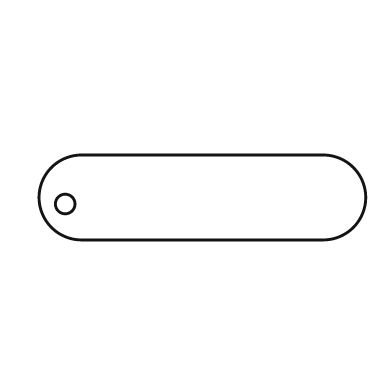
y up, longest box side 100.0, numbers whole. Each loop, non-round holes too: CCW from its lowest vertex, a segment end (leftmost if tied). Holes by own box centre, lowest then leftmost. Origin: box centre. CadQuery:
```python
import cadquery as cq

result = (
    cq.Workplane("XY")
    .moveTo(-37.0, -13.0)
    .lineTo(37.0, -13.0)
    .threePointArc((50.0, 0.0), (37.0, 13.0))
    .lineTo(-37.0, 13.0)
    .threePointArc((-50.0, 0.0), (-37.0, -13.0))
    .close()
    .moveTo(-42.0, -2.0)
    .circle(3.0)
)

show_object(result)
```